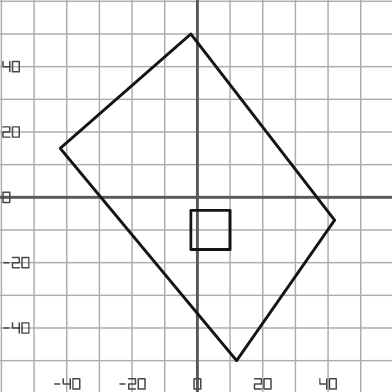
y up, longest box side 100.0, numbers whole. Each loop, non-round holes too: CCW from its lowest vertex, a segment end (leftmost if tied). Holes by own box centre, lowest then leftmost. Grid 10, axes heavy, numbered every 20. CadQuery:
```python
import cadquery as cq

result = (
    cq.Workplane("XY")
    .moveTo(12.0, -50.0)
    .lineTo(42.0, -7.0)
    .lineTo(-2.0, 50.0)
    .lineTo(-42.0, 15.0)
    .close()
    .moveTo(-2.0, -16.0)
    .lineTo(10.0, -16.0)
    .lineTo(10.0, -4.0)
    .lineTo(-2.0, -4.0)
    .close()
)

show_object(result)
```